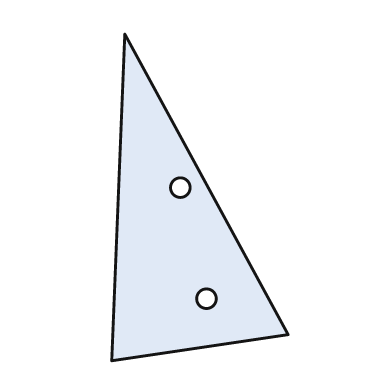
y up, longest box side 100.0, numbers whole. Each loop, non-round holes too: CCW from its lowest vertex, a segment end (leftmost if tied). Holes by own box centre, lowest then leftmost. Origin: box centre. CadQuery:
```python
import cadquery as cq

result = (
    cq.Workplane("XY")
    .moveTo(-27.0, -50.0)
    .lineTo(27.0, -42.0)
    .lineTo(-23.0, 50.0)
    .close()
    .moveTo(2.0, -31.0)
    .circle(3.0)
    .moveTo(-6.0, 3.0)
    .circle(3.0)
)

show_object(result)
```